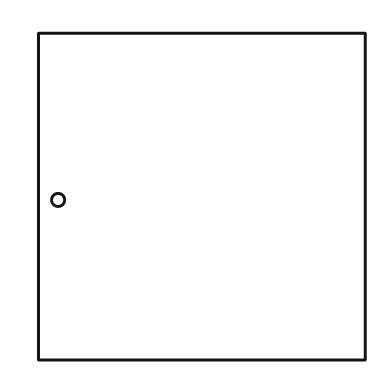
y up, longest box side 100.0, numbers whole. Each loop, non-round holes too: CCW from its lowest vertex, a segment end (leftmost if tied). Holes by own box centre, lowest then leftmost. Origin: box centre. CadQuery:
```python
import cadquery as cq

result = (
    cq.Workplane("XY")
    .moveTo(-50.0, -50.0)
    .lineTo(50.0, -50.0)
    .lineTo(50.0, 50.0)
    .lineTo(-50.0, 50.0)
    .close()
    .moveTo(-44.0, -1.0)
    .circle(2.0)
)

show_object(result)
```